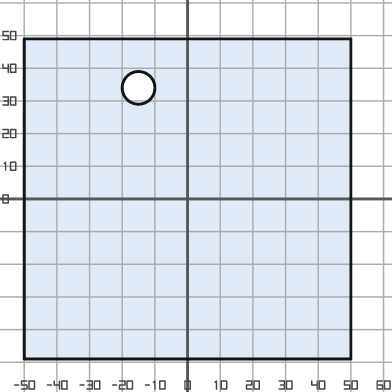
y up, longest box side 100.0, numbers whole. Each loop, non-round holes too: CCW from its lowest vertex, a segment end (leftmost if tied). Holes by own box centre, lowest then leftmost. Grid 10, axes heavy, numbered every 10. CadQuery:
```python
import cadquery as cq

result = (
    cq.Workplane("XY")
    .moveTo(-50.0, -49.0)
    .lineTo(50.0, -49.0)
    .lineTo(50.0, 49.0)
    .lineTo(-50.0, 49.0)
    .close()
    .moveTo(-15.0, 34.0)
    .circle(5.0)
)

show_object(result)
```